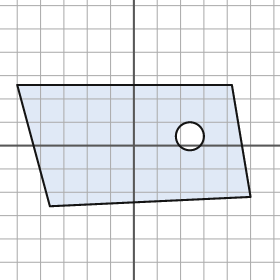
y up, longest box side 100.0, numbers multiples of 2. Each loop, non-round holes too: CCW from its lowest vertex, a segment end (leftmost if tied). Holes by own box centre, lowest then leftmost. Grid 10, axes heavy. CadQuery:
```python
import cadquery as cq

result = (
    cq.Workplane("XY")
    .moveTo(-36.0, -26.0)
    .lineTo(50.0, -22.0)
    .lineTo(42.0, 26.0)
    .lineTo(-50.0, 26.0)
    .close()
    .moveTo(24.0, 4.0)
    .circle(6.0)
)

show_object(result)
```